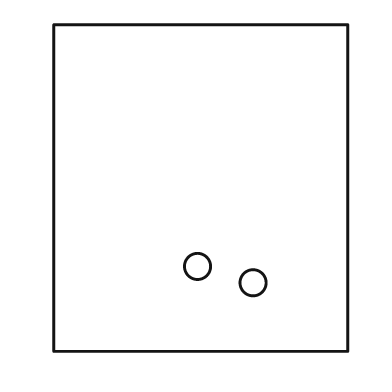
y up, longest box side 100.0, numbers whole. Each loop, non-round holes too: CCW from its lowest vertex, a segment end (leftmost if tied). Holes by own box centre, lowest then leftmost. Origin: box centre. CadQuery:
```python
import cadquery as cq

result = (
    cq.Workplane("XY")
    .moveTo(-45.0, -50.0)
    .lineTo(45.0, -50.0)
    .lineTo(45.0, 50.0)
    .lineTo(-45.0, 50.0)
    .close()
    .moveTo(16.0, -29.0)
    .circle(4.0)
    .moveTo(-1.0, -24.0)
    .circle(4.0)
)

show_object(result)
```